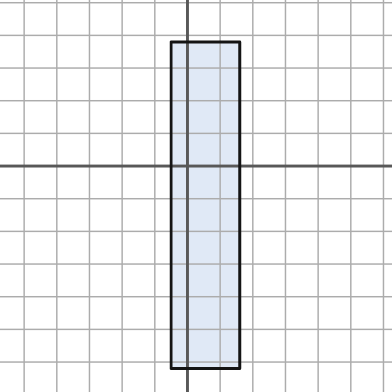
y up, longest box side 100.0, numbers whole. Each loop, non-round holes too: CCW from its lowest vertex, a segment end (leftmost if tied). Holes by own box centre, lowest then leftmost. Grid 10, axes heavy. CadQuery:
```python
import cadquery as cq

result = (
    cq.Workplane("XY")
    .moveTo(-5.0, -62.0)
    .lineTo(16.0, -62.0)
    .lineTo(16.0, 38.0)
    .lineTo(-5.0, 38.0)
    .close()
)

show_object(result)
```